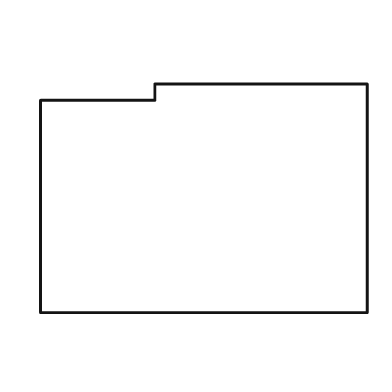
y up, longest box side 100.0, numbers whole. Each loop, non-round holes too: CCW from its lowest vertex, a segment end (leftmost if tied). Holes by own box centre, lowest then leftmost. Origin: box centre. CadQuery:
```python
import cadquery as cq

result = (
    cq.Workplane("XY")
    .moveTo(-50.0, -35.0)
    .lineTo(50.0, -35.0)
    .lineTo(50.0, 35.0)
    .lineTo(-15.0, 35.0)
    .lineTo(-15.0, 30.0)
    .lineTo(-50.0, 30.0)
    .close()
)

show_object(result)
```